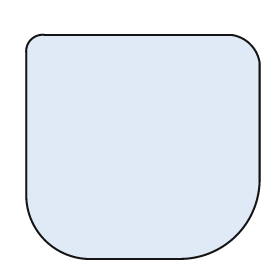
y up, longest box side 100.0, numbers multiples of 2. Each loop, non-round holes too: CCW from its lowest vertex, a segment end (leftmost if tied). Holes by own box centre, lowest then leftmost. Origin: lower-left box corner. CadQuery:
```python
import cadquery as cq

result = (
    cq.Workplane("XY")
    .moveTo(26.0, 0.0)
    .lineTo(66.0, 0.0)
    .threePointArc((90.0, 10.0), (100.0, 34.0))
    .lineTo(100.0, 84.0)
    .threePointArc((96.0, 92.0), (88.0, 96.0))
    .lineTo(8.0, 96.0)
    .threePointArc((2.0, 94.0), (0.0, 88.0))
    .lineTo(0.0, 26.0)
    .threePointArc((8.0, 8.0), (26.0, 0.0))
    .close()
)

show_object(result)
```